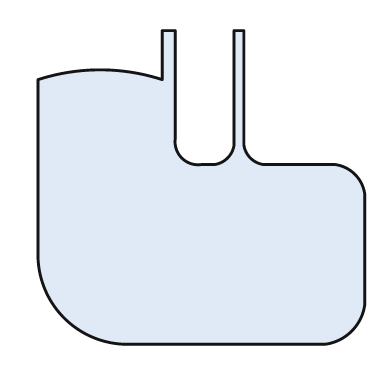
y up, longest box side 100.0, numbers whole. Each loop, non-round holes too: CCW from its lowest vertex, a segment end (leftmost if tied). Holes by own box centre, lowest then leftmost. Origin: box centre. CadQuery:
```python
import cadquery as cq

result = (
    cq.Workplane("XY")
    .moveTo(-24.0, -48.0)
    .lineTo(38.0, -48.0)
    .threePointArc((46.0, -44.0), (50.0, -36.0))
    .lineTo(50.0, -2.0)
    .threePointArc((47.0, 4.0), (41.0, 7.0))
    .lineTo(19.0, 7.0)
    .threePointArc((15.0, 9.0), (13.0, 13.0))
    .lineTo(13.0, 48.0)
    .lineTo(10.0, 48.0)
    .lineTo(10.0, 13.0)
    .threePointArc((8.0, 9.0), (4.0, 7.0))
    .lineTo(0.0, 7.0)
    .threePointArc((-6.0, 9.0), (-8.0, 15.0))
    .lineTo(-8.0, 48.0)
    .lineTo(-12.0, 48.0)
    .lineTo(-12.0, 33.0)
    .threePointArc((-31.0, 36.0), (-50.0, 33.0))
    .lineTo(-50.0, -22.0)
    .threePointArc((-42.0, -40.0), (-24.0, -48.0))
    .close()
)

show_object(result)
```